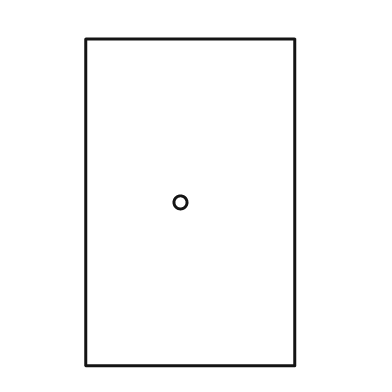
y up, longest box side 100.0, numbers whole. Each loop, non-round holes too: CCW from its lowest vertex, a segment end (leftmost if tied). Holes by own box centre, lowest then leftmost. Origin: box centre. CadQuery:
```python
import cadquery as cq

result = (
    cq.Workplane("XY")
    .moveTo(-32.0, -50.0)
    .lineTo(32.0, -50.0)
    .lineTo(32.0, 50.0)
    .lineTo(-32.0, 50.0)
    .close()
    .moveTo(-3.0, 0.0)
    .circle(2.0)
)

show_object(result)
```